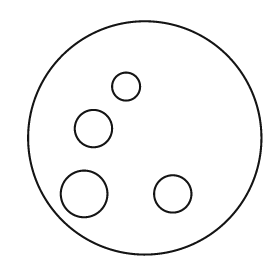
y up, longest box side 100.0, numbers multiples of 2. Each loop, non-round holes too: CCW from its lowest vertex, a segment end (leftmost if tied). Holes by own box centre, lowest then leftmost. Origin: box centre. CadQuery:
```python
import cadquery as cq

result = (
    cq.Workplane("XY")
    .moveTo(0.0, 0.0)
    .circle(50.0)
    .moveTo(-26.0, -24.0)
    .circle(10.0)
    .moveTo(12.0, -24.0)
    .circle(8.0)
    .moveTo(-22.0, 4.0)
    .circle(8.0)
    .moveTo(-8.0, 22.0)
    .circle(6.0)
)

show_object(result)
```